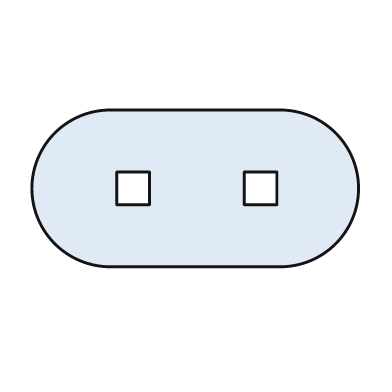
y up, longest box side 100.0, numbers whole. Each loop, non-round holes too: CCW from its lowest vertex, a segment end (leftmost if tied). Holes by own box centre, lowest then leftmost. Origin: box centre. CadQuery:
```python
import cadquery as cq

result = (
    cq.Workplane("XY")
    .moveTo(-26.0, -24.0)
    .lineTo(26.0, -24.0)
    .threePointArc((50.0, 0.0), (26.0, 24.0))
    .lineTo(-26.0, 24.0)
    .threePointArc((-50.0, 0.0), (-26.0, -24.0))
    .close()
    .moveTo(-24.0, -5.0)
    .lineTo(-14.0, -5.0)
    .lineTo(-14.0, 5.0)
    .lineTo(-24.0, 5.0)
    .close()
    .moveTo(15.0, -5.0)
    .lineTo(25.0, -5.0)
    .lineTo(25.0, 5.0)
    .lineTo(15.0, 5.0)
    .close()
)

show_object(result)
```